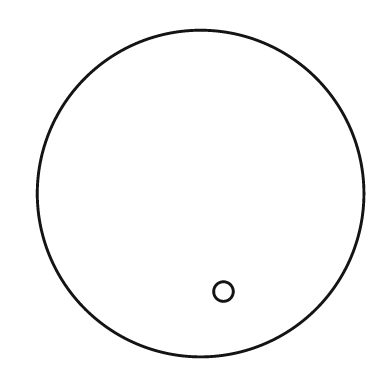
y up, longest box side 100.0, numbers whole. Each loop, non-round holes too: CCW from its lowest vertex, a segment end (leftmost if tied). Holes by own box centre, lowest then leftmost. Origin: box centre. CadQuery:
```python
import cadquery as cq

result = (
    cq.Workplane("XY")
    .moveTo(0.0, 0.0)
    .circle(50.0)
    .moveTo(7.0, -30.0)
    .circle(3.0)
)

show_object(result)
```